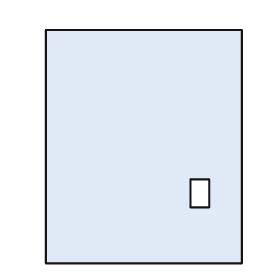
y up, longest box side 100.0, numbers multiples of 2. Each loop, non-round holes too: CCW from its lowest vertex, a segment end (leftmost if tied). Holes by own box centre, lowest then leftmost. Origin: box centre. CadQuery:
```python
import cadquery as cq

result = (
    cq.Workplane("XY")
    .moveTo(-42.0, -50.0)
    .lineTo(42.0, -50.0)
    .lineTo(42.0, 50.0)
    .lineTo(-42.0, 50.0)
    .close()
    .moveTo(20.0, -26.0)
    .lineTo(28.0, -26.0)
    .lineTo(28.0, -14.0)
    .lineTo(20.0, -14.0)
    .close()
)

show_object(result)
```